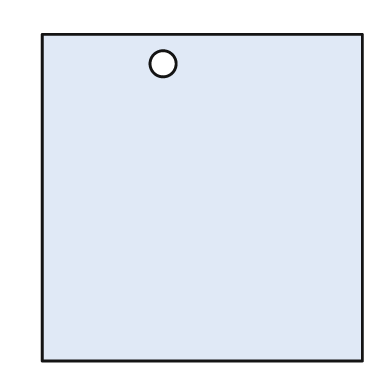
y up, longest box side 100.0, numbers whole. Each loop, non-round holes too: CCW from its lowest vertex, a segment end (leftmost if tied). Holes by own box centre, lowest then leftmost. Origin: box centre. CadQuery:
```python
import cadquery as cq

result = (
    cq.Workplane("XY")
    .moveTo(-49.0, -50.0)
    .lineTo(49.0, -50.0)
    .lineTo(49.0, 50.0)
    .lineTo(-49.0, 50.0)
    .close()
    .moveTo(-12.0, 41.0)
    .circle(4.0)
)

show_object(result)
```